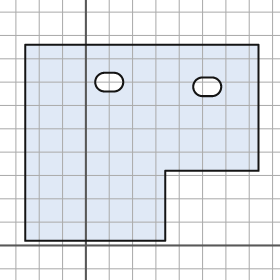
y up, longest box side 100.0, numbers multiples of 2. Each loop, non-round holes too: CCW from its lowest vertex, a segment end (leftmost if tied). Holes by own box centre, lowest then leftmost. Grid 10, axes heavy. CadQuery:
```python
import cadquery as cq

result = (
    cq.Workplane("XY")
    .moveTo(-26.0, 2.0)
    .lineTo(34.0, 2.0)
    .lineTo(34.0, 32.0)
    .lineTo(74.0, 32.0)
    .lineTo(74.0, 86.0)
    .lineTo(-26.0, 86.0)
    .close()
    .moveTo(50.0, 64.0)
    .lineTo(54.0, 64.0)
    .threePointArc((58.0, 68.0), (54.0, 72.0))
    .lineTo(50.0, 72.0)
    .threePointArc((46.0, 68.0), (50.0, 64.0))
    .close()
    .moveTo(8.0, 66.0)
    .lineTo(12.0, 66.0)
    .threePointArc((16.0, 70.0), (12.0, 74.0))
    .lineTo(8.0, 74.0)
    .threePointArc((4.0, 70.0), (8.0, 66.0))
    .close()
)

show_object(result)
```